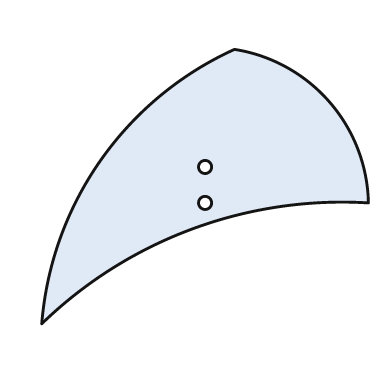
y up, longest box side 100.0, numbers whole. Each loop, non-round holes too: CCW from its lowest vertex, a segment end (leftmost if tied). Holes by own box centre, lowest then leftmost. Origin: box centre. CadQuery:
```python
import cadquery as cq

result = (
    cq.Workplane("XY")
    .moveTo(-50.0, -42.0)
    .threePointArc((-4.0, -13.0), (50.0, -5.0))
    .threePointArc((38.0, 26.0), (9.0, 42.0))
    .threePointArc((-32.0, 8.0), (-50.0, -42.0))
    .close()
    .moveTo(0.0, -5.0)
    .circle(2.0)
    .moveTo(0.0, 6.0)
    .circle(2.0)
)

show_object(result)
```